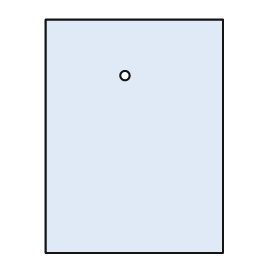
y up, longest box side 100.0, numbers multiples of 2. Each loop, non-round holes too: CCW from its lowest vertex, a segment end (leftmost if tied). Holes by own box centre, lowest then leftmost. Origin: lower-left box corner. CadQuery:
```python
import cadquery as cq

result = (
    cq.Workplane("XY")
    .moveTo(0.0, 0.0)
    .lineTo(76.0, 0.0)
    .lineTo(76.0, 100.0)
    .lineTo(0.0, 100.0)
    .close()
    .moveTo(34.0, 76.0)
    .circle(2.0)
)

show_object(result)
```